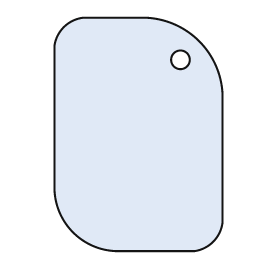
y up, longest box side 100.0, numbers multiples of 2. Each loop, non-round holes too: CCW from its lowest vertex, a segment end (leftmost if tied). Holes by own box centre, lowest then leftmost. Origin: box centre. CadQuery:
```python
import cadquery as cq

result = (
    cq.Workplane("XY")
    .moveTo(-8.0, -50.0)
    .lineTo(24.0, -50.0)
    .threePointArc((32.0, -46.0), (36.0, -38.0))
    .lineTo(36.0, 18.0)
    .threePointArc((26.0, 40.0), (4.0, 50.0))
    .lineTo(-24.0, 50.0)
    .threePointArc((-32.0, 46.0), (-36.0, 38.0))
    .lineTo(-36.0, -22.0)
    .threePointArc((-28.0, -42.0), (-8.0, -50.0))
    .close()
    .moveTo(18.0, 32.0)
    .circle(4.0)
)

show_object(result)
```